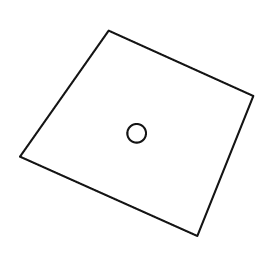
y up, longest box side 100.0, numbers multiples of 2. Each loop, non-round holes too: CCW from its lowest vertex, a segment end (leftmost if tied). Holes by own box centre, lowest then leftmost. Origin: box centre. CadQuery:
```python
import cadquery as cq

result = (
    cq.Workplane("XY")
    .moveTo(26.0, -44.0)
    .lineTo(50.0, 16.0)
    .lineTo(-12.0, 44.0)
    .lineTo(-50.0, -10.0)
    .close()
    .moveTo(0.0, 0.0)
    .circle(4.0)
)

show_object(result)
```